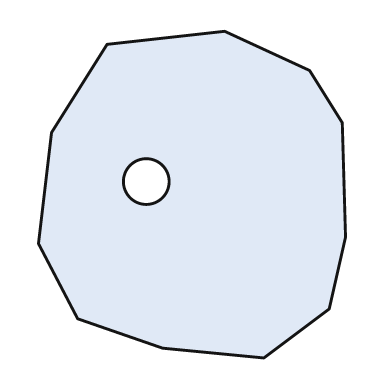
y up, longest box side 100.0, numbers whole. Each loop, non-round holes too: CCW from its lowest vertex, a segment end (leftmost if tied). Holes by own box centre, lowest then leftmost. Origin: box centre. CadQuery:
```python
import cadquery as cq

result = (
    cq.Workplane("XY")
    .moveTo(22.0, -50.0)
    .lineTo(42.0, -35.0)
    .lineTo(47.0, -13.0)
    .lineTo(46.0, 22.0)
    .lineTo(36.0, 38.0)
    .lineTo(10.0, 50.0)
    .lineTo(-26.0, 46.0)
    .lineTo(-43.0, 19.0)
    .lineTo(-47.0, -15.0)
    .lineTo(-35.0, -38.0)
    .lineTo(-9.0, -47.0)
    .close()
    .moveTo(-14.0, 4.0)
    .circle(7.0)
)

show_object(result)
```